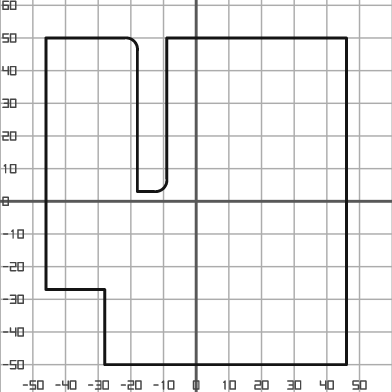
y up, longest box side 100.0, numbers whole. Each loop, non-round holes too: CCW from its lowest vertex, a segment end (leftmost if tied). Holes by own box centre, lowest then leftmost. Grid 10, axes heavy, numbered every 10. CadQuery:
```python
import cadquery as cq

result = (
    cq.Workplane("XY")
    .moveTo(-28.0, -50.0)
    .lineTo(46.0, -50.0)
    .lineTo(46.0, 50.0)
    .lineTo(-9.0, 50.0)
    .lineTo(-9.0, 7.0)
    .threePointArc((-10.0, 4.0), (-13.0, 3.0))
    .lineTo(-18.0, 3.0)
    .lineTo(-18.0, 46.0)
    .threePointArc((-19.0, 49.0), (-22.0, 50.0))
    .lineTo(-46.0, 50.0)
    .lineTo(-46.0, -27.0)
    .lineTo(-28.0, -27.0)
    .close()
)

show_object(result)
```